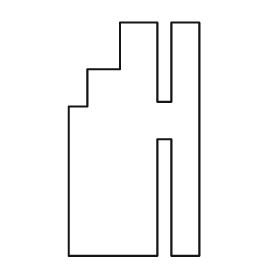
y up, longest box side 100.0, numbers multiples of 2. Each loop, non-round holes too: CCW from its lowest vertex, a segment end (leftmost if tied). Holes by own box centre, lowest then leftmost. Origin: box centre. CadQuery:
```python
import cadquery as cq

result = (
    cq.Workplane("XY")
    .moveTo(-28.0, -50.0)
    .lineTo(10.0, -50.0)
    .lineTo(10.0, 0.0)
    .lineTo(16.0, 0.0)
    .lineTo(16.0, -50.0)
    .lineTo(28.0, -50.0)
    .lineTo(28.0, 50.0)
    .lineTo(16.0, 50.0)
    .lineTo(16.0, 16.0)
    .lineTo(10.0, 16.0)
    .lineTo(10.0, 50.0)
    .lineTo(-6.0, 50.0)
    .lineTo(-6.0, 30.0)
    .lineTo(-20.0, 30.0)
    .lineTo(-20.0, 14.0)
    .lineTo(-28.0, 14.0)
    .close()
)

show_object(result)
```